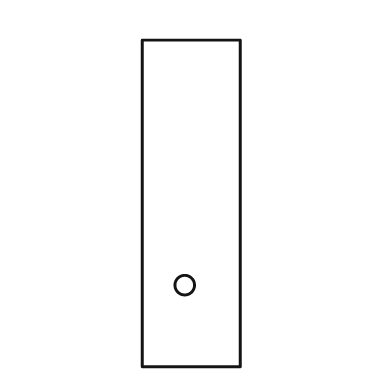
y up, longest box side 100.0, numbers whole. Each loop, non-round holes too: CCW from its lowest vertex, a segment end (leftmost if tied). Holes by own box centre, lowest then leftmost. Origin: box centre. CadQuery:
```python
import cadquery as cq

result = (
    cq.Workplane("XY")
    .moveTo(-15.0, -50.0)
    .lineTo(15.0, -50.0)
    .lineTo(15.0, 50.0)
    .lineTo(-15.0, 50.0)
    .close()
    .moveTo(-2.0, -25.0)
    .circle(3.0)
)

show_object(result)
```